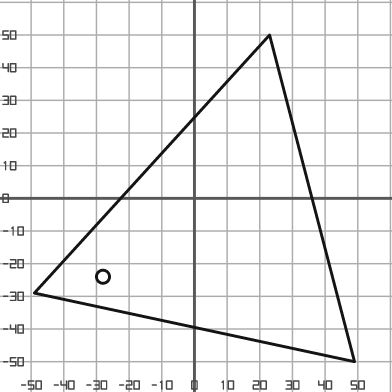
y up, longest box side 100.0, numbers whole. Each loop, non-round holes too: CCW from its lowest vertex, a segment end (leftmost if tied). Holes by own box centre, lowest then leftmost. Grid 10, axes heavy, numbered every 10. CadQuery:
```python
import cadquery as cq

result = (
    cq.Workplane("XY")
    .moveTo(49.0, -50.0)
    .lineTo(23.0, 50.0)
    .lineTo(-49.0, -29.0)
    .close()
    .moveTo(-28.0, -24.0)
    .circle(2.0)
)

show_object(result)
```